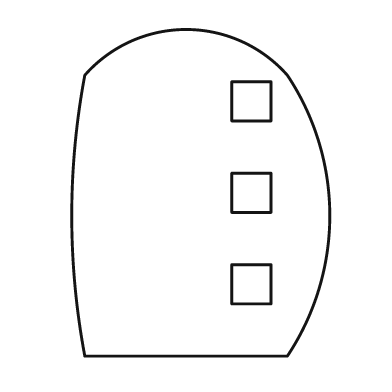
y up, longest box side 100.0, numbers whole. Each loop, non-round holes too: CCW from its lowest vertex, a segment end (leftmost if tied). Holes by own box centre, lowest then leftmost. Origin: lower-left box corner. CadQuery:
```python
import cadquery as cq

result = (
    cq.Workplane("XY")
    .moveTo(4.0, 0.0)
    .lineTo(66.0, 0.0)
    .threePointArc((79.0, 43.0), (66.0, 86.0))
    .threePointArc((35.0, 100.0), (4.0, 86.0))
    .threePointArc((0.0, 43.0), (4.0, 0.0))
    .close()
    .moveTo(49.0, 16.0)
    .lineTo(61.0, 16.0)
    .lineTo(61.0, 28.0)
    .lineTo(49.0, 28.0)
    .close()
    .moveTo(49.0, 44.0)
    .lineTo(61.0, 44.0)
    .lineTo(61.0, 56.0)
    .lineTo(49.0, 56.0)
    .close()
    .moveTo(49.0, 72.0)
    .lineTo(61.0, 72.0)
    .lineTo(61.0, 84.0)
    .lineTo(49.0, 84.0)
    .close()
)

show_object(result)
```